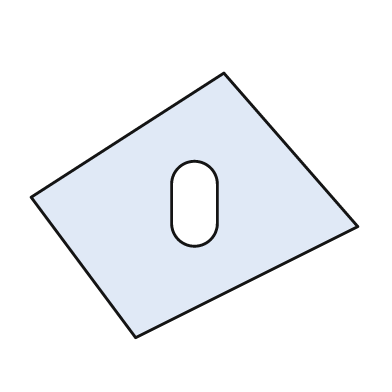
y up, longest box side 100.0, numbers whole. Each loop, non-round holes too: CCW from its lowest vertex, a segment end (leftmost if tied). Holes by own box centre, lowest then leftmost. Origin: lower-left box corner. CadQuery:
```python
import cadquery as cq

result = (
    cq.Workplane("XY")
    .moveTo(32.0, 0.0)
    .lineTo(100.0, 34.0)
    .lineTo(59.0, 81.0)
    .lineTo(0.0, 43.0)
    .close()
    .moveTo(43.0, 35.0)
    .threePointArc((50.0, 28.0), (57.0, 35.0))
    .lineTo(57.0, 47.0)
    .threePointArc((50.0, 54.0), (43.0, 47.0))
    .close()
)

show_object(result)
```